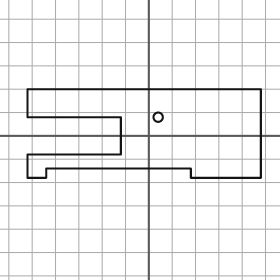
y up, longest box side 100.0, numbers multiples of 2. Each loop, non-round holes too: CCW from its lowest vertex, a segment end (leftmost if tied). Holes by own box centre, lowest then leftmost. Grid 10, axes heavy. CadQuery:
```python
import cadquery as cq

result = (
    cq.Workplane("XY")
    .moveTo(-52.0, -18.0)
    .lineTo(-44.0, -18.0)
    .lineTo(-44.0, -14.0)
    .lineTo(18.0, -14.0)
    .lineTo(18.0, -18.0)
    .lineTo(48.0, -18.0)
    .lineTo(48.0, 20.0)
    .lineTo(-52.0, 20.0)
    .lineTo(-52.0, 8.0)
    .lineTo(-12.0, 8.0)
    .lineTo(-12.0, -8.0)
    .lineTo(-52.0, -8.0)
    .close()
    .moveTo(4.0, 8.0)
    .circle(2.0)
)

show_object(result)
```